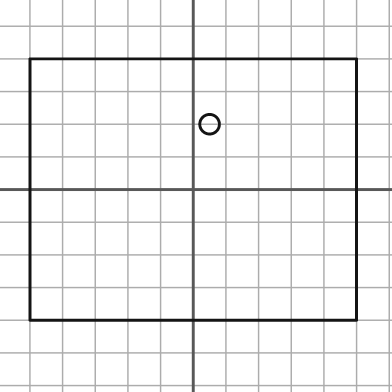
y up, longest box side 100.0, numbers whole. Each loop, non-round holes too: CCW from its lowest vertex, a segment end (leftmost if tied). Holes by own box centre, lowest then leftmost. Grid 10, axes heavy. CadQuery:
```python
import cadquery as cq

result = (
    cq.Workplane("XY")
    .moveTo(-50.0, -40.0)
    .lineTo(50.0, -40.0)
    .lineTo(50.0, 40.0)
    .lineTo(-50.0, 40.0)
    .close()
    .moveTo(5.0, 20.0)
    .circle(3.0)
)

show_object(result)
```